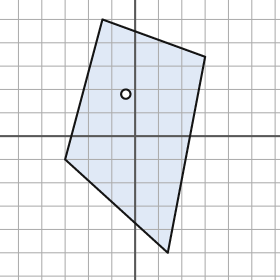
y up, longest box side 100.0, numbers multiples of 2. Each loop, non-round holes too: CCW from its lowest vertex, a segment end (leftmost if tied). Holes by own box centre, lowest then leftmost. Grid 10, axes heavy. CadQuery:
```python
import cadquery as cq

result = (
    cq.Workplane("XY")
    .moveTo(14.0, -50.0)
    .lineTo(30.0, 34.0)
    .lineTo(-14.0, 50.0)
    .lineTo(-30.0, -10.0)
    .close()
    .moveTo(-4.0, 18.0)
    .circle(2.0)
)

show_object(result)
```